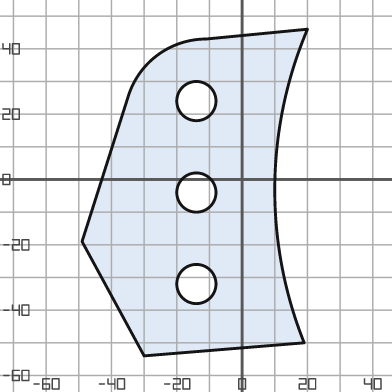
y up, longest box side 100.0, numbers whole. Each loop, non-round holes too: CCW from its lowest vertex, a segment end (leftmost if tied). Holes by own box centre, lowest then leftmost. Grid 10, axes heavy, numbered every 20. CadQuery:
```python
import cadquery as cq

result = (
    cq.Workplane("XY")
    .moveTo(-30.0, -54.0)
    .lineTo(19.0, -50.0)
    .threePointArc((10.0, -2.0), (20.0, 46.0))
    .lineTo(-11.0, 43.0)
    .threePointArc((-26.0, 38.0), (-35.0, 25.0))
    .lineTo(-49.0, -19.0)
    .close()
    .moveTo(-14.0, -32.0)
    .circle(6.0)
    .moveTo(-14.0, -4.0)
    .circle(6.0)
    .moveTo(-14.0, 24.0)
    .circle(6.0)
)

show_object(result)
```